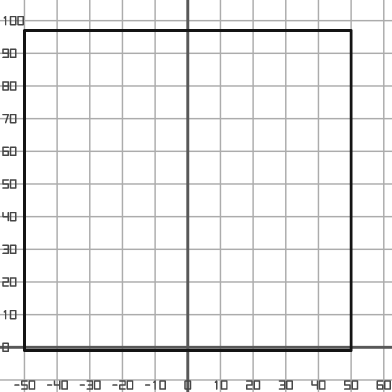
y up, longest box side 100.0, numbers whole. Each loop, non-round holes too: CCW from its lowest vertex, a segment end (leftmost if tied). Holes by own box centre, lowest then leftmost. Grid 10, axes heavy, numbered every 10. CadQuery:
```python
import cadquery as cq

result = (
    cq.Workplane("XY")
    .moveTo(-50.0, -1.0)
    .lineTo(50.0, -1.0)
    .lineTo(50.0, 97.0)
    .lineTo(-50.0, 97.0)
    .close()
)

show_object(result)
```